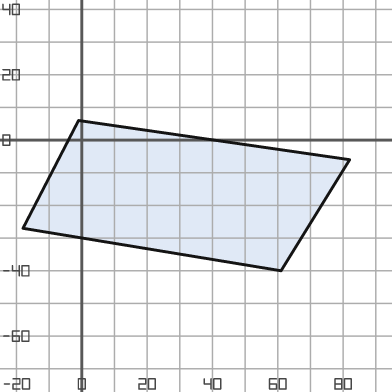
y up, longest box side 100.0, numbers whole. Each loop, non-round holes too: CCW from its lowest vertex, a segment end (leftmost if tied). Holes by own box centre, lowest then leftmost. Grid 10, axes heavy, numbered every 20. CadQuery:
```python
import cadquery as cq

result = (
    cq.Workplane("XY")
    .moveTo(61.0, -40.0)
    .lineTo(82.0, -6.0)
    .lineTo(-1.0, 6.0)
    .lineTo(-18.0, -27.0)
    .close()
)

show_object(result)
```